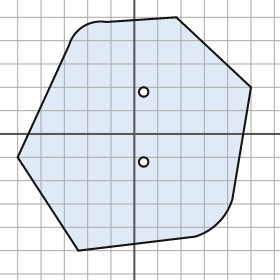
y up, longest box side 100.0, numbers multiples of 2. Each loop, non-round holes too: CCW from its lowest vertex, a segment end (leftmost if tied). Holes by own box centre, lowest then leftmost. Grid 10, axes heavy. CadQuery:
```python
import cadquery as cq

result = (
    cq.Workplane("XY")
    .moveTo(-24.0, -50.0)
    .lineTo(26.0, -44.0)
    .threePointArc((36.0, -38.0), (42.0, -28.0))
    .lineTo(50.0, 20.0)
    .lineTo(18.0, 50.0)
    .lineTo(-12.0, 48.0)
    .threePointArc((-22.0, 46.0), (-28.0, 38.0))
    .lineTo(-50.0, -10.0)
    .close()
    .moveTo(4.0, -12.0)
    .circle(2.0)
    .moveTo(4.0, 18.0)
    .circle(2.0)
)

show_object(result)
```